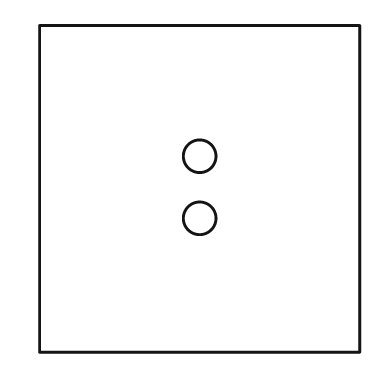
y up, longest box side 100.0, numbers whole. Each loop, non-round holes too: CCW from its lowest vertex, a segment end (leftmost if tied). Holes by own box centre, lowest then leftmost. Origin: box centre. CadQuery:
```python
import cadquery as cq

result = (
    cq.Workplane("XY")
    .moveTo(-49.0, -50.0)
    .lineTo(49.0, -50.0)
    .lineTo(49.0, 50.0)
    .lineTo(-49.0, 50.0)
    .close()
    .moveTo(0.0, -9.0)
    .circle(5.0)
    .moveTo(0.0, 10.0)
    .circle(5.0)
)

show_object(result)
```